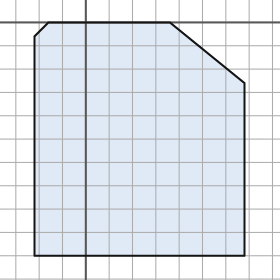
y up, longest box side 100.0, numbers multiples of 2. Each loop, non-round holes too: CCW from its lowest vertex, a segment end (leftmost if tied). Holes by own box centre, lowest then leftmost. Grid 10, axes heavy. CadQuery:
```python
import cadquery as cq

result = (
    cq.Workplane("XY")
    .moveTo(-22.0, -100.0)
    .lineTo(68.0, -100.0)
    .lineTo(68.0, -26.0)
    .lineTo(36.0, 0.0)
    .lineTo(-16.0, 0.0)
    .lineTo(-22.0, -6.0)
    .close()
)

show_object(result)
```